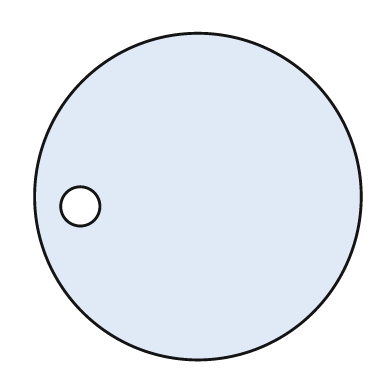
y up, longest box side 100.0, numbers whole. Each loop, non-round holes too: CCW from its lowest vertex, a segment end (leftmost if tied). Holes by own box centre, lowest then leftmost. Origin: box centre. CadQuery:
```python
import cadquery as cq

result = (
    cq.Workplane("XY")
    .moveTo(0.0, 0.0)
    .circle(50.0)
    .moveTo(-36.0, -3.0)
    .circle(6.0)
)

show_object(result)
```